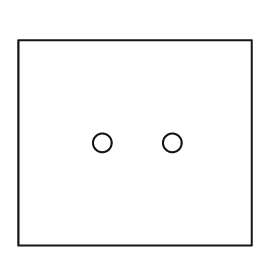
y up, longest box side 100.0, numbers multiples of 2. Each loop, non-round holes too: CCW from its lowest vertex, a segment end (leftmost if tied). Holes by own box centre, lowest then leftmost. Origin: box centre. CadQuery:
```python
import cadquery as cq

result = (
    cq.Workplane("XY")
    .moveTo(-50.0, -44.0)
    .lineTo(50.0, -44.0)
    .lineTo(50.0, 44.0)
    .lineTo(-50.0, 44.0)
    .close()
    .moveTo(-14.0, 0.0)
    .circle(4.0)
    .moveTo(16.0, 0.0)
    .circle(4.0)
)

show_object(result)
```